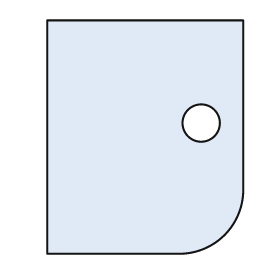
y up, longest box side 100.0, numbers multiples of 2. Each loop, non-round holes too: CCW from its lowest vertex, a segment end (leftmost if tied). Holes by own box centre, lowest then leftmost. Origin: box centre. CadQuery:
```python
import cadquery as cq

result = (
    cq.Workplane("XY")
    .moveTo(-42.0, -50.0)
    .lineTo(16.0, -50.0)
    .threePointArc((34.0, -42.0), (42.0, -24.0))
    .lineTo(42.0, 50.0)
    .lineTo(-42.0, 50.0)
    .close()
    .moveTo(24.0, 6.0)
    .circle(8.0)
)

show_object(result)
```